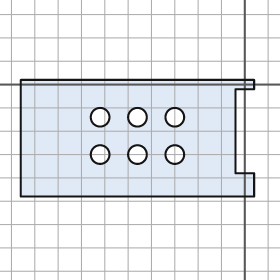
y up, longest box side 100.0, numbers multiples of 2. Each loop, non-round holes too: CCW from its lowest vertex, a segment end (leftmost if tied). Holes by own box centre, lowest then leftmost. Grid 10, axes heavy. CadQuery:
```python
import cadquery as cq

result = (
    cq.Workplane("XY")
    .moveTo(-96.0, -48.0)
    .lineTo(4.0, -48.0)
    .lineTo(4.0, -38.0)
    .lineTo(-4.0, -38.0)
    .lineTo(-4.0, -2.0)
    .lineTo(4.0, -2.0)
    .lineTo(4.0, 2.0)
    .lineTo(-96.0, 2.0)
    .close()
    .moveTo(-62.0, -30.0)
    .circle(4.0)
    .moveTo(-46.0, -30.0)
    .circle(4.0)
    .moveTo(-30.0, -30.0)
    .circle(4.0)
    .moveTo(-62.0, -14.0)
    .circle(4.0)
    .moveTo(-46.0, -14.0)
    .circle(4.0)
    .moveTo(-30.0, -14.0)
    .circle(4.0)
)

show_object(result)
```